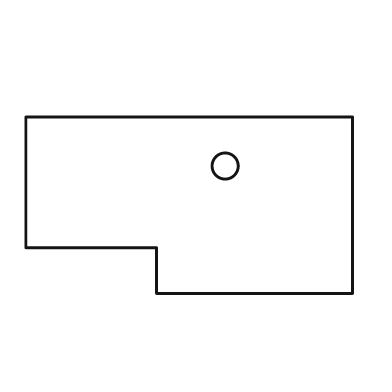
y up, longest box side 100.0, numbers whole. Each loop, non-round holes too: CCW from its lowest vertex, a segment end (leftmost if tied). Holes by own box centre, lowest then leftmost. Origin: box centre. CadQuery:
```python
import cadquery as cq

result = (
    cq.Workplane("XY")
    .moveTo(-10.0, -27.0)
    .lineTo(50.0, -27.0)
    .lineTo(50.0, 27.0)
    .lineTo(-50.0, 27.0)
    .lineTo(-50.0, -13.0)
    .lineTo(-10.0, -13.0)
    .close()
    .moveTo(11.0, 12.0)
    .circle(4.0)
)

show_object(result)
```